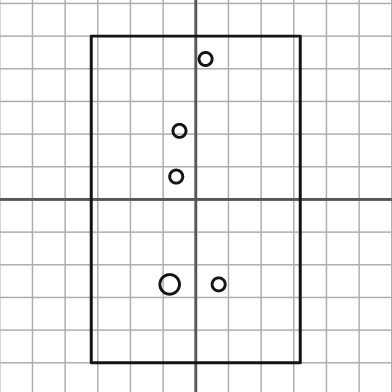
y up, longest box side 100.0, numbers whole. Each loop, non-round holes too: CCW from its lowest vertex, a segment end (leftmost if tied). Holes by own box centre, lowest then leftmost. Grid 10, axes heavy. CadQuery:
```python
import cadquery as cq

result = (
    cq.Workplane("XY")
    .moveTo(-32.0, -50.0)
    .lineTo(32.0, -50.0)
    .lineTo(32.0, 50.0)
    .lineTo(-32.0, 50.0)
    .close()
    .moveTo(-8.0, -26.0)
    .circle(3.0)
    .moveTo(7.0, -26.0)
    .circle(2.0)
    .moveTo(-6.0, 7.0)
    .circle(2.0)
    .moveTo(-5.0, 21.0)
    .circle(2.0)
    .moveTo(3.0, 43.0)
    .circle(2.0)
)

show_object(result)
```